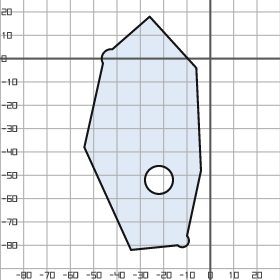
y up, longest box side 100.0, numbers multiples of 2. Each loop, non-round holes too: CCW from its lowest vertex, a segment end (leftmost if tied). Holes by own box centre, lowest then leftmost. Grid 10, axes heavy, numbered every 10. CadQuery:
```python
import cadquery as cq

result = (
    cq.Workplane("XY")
    .moveTo(-34.0, -82.0)
    .lineTo(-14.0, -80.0)
    .threePointArc((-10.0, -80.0), (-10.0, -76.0))
    .lineTo(-4.0, -48.0)
    .lineTo(-6.0, -4.0)
    .lineTo(-26.0, 18.0)
    .lineTo(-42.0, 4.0)
    .threePointArc((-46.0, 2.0), (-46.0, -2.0))
    .lineTo(-54.0, -38.0)
    .close()
    .moveTo(-22.0, -52.0)
    .circle(6.0)
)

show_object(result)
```